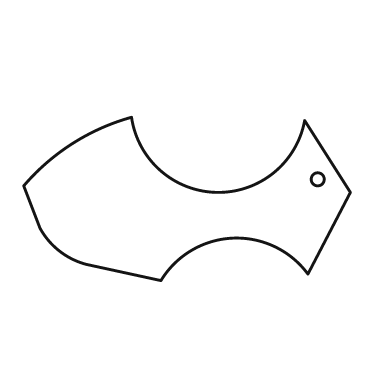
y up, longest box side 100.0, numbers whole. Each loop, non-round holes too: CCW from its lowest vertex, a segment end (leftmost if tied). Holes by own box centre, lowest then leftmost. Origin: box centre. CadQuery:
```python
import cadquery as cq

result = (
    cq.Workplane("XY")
    .moveTo(-8.0, -25.0)
    .threePointArc((14.0, -12.0), (37.0, -23.0))
    .lineTo(50.0, 2.0)
    .lineTo(36.0, 24.0)
    .threePointArc((9.0, 2.0), (-17.0, 25.0))
    .threePointArc((-35.0, 17.0), (-50.0, 4.0))
    .lineTo(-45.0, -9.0)
    .threePointArc((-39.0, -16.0), (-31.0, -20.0))
    .close()
    .moveTo(40.0, 6.0)
    .circle(2.0)
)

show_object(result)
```